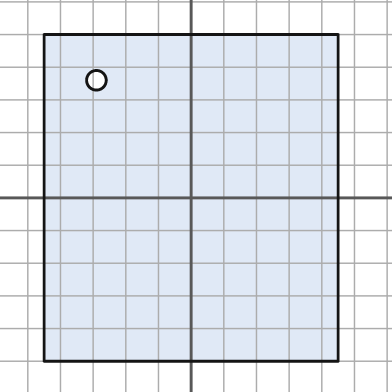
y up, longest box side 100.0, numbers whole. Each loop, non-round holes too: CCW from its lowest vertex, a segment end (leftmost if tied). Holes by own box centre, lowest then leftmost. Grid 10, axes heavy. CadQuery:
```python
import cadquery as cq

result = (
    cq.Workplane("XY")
    .moveTo(-45.0, -50.0)
    .lineTo(45.0, -50.0)
    .lineTo(45.0, 50.0)
    .lineTo(-45.0, 50.0)
    .close()
    .moveTo(-29.0, 36.0)
    .circle(3.0)
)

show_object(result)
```